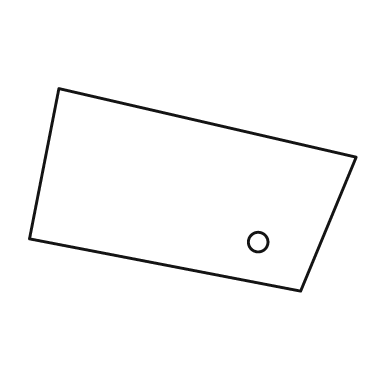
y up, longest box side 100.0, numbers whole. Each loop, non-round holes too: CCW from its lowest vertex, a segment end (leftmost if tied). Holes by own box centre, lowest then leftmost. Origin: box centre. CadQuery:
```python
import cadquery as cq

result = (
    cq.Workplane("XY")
    .moveTo(33.0, -31.0)
    .lineTo(50.0, 10.0)
    .lineTo(-41.0, 31.0)
    .lineTo(-50.0, -15.0)
    .close()
    .moveTo(20.0, -16.0)
    .circle(3.0)
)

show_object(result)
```